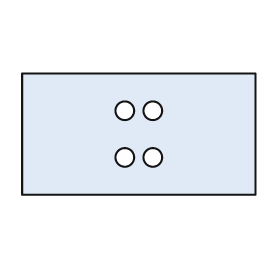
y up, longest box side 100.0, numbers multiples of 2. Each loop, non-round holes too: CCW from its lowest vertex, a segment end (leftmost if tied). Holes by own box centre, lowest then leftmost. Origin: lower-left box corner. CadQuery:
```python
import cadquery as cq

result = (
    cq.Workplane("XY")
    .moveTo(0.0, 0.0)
    .lineTo(100.0, 0.0)
    .lineTo(100.0, 52.0)
    .lineTo(0.0, 52.0)
    .close()
    .moveTo(44.0, 16.0)
    .circle(4.0)
    .moveTo(56.0, 16.0)
    .circle(4.0)
    .moveTo(44.0, 36.0)
    .circle(4.0)
    .moveTo(56.0, 36.0)
    .circle(4.0)
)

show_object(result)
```